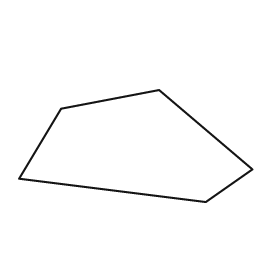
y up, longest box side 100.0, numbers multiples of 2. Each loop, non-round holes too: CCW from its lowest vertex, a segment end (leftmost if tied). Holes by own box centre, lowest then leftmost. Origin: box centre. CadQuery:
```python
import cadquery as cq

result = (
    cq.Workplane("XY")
    .moveTo(30.0, -24.0)
    .lineTo(50.0, -10.0)
    .lineTo(10.0, 24.0)
    .lineTo(-32.0, 16.0)
    .lineTo(-50.0, -14.0)
    .close()
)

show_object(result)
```